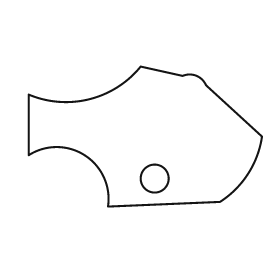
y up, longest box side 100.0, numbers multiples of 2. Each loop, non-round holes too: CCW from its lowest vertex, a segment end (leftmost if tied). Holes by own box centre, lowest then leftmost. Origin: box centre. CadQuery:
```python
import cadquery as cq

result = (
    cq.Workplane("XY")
    .moveTo(-16.0, -30.0)
    .lineTo(32.0, -28.0)
    .threePointArc((44.0, -16.0), (50.0, 0.0))
    .lineTo(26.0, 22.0)
    .threePointArc((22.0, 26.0), (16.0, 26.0))
    .lineTo(-2.0, 30.0)
    .threePointArc((-24.0, 16.0), (-50.0, 18.0))
    .lineTo(-50.0, -8.0)
    .threePointArc((-26.0, -8.0), (-16.0, -30.0))
    .close()
    .moveTo(4.0, -18.0)
    .circle(6.0)
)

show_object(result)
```